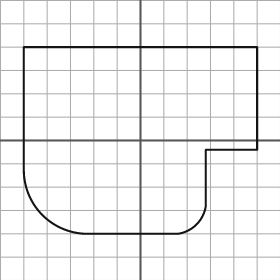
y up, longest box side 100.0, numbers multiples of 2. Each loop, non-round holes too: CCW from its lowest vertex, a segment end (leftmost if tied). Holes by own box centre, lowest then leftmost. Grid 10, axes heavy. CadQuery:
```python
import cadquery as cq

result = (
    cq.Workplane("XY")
    .moveTo(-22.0, -40.0)
    .lineTo(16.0, -40.0)
    .threePointArc((24.0, -36.0), (28.0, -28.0))
    .lineTo(28.0, -4.0)
    .lineTo(50.0, -4.0)
    .lineTo(50.0, 40.0)
    .lineTo(-50.0, 40.0)
    .lineTo(-50.0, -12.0)
    .threePointArc((-42.0, -32.0), (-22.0, -40.0))
    .close()
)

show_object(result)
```